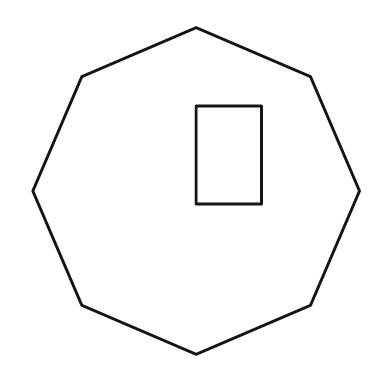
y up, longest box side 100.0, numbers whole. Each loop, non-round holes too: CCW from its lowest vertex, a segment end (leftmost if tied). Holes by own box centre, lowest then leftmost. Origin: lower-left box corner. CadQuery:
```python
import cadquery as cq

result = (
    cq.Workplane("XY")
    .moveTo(50.0, 0.0)
    .lineTo(85.0, 15.0)
    .lineTo(100.0, 50.0)
    .lineTo(85.0, 85.0)
    .lineTo(50.0, 100.0)
    .lineTo(15.0, 85.0)
    .lineTo(0.0, 50.0)
    .lineTo(15.0, 15.0)
    .close()
    .moveTo(50.0, 46.0)
    .lineTo(70.0, 46.0)
    .lineTo(70.0, 76.0)
    .lineTo(50.0, 76.0)
    .close()
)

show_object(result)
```